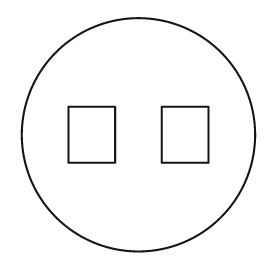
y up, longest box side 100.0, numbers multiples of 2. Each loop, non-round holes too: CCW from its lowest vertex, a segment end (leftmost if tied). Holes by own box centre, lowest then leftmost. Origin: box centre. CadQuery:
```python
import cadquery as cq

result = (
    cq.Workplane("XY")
    .moveTo(0.0, 0.0)
    .circle(50.0)
    .moveTo(-30.0, -12.0)
    .lineTo(-10.0, -12.0)
    .lineTo(-10.0, 12.0)
    .lineTo(-30.0, 12.0)
    .close()
    .moveTo(10.0, -12.0)
    .lineTo(30.0, -12.0)
    .lineTo(30.0, 12.0)
    .lineTo(10.0, 12.0)
    .close()
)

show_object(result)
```